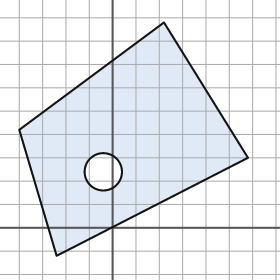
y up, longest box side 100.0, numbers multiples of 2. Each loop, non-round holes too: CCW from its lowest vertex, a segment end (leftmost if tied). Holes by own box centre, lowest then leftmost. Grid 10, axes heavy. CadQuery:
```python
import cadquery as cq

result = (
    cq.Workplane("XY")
    .moveTo(-24.0, -12.0)
    .lineTo(58.0, 30.0)
    .lineTo(22.0, 88.0)
    .lineTo(-40.0, 42.0)
    .close()
    .moveTo(-4.0, 24.0)
    .circle(8.0)
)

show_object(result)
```